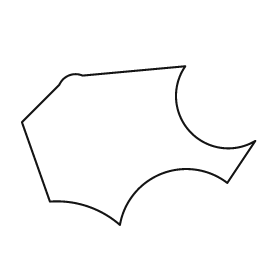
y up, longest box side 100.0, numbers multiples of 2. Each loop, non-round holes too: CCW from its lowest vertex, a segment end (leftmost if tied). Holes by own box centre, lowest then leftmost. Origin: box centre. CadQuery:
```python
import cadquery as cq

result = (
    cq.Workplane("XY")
    .moveTo(-8.0, -34.0)
    .threePointArc((10.0, -12.0), (38.0, -16.0))
    .lineTo(50.0, 2.0)
    .threePointArc((22.0, 6.0), (20.0, 34.0))
    .lineTo(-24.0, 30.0)
    .threePointArc((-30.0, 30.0), (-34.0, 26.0))
    .lineTo(-50.0, 10.0)
    .lineTo(-38.0, -24.0)
    .threePointArc((-22.0, -26.0), (-8.0, -34.0))
    .close()
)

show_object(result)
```